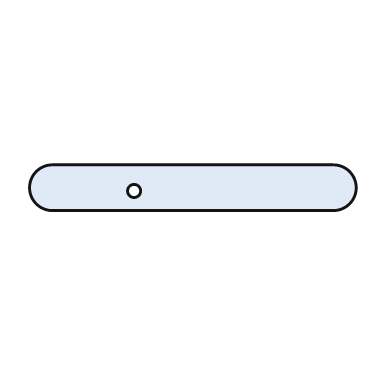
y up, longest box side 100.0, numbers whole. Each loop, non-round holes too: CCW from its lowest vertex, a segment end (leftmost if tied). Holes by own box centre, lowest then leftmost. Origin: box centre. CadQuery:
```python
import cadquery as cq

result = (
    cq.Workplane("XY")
    .moveTo(-43.0, -7.0)
    .lineTo(43.0, -7.0)
    .threePointArc((50.0, 0.0), (43.0, 7.0))
    .lineTo(-43.0, 7.0)
    .threePointArc((-50.0, 0.0), (-43.0, -7.0))
    .close()
    .moveTo(-18.0, -1.0)
    .circle(2.0)
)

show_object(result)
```